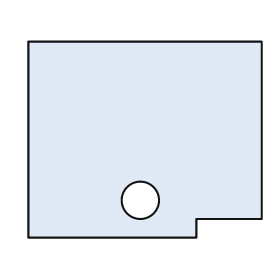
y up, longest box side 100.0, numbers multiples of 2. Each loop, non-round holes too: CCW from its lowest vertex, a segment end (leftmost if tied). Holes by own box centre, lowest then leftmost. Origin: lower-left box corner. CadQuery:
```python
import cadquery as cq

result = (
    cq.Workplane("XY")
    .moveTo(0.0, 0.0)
    .lineTo(72.0, 0.0)
    .lineTo(72.0, 8.0)
    .lineTo(100.0, 8.0)
    .lineTo(100.0, 84.0)
    .lineTo(0.0, 84.0)
    .close()
    .moveTo(48.0, 16.0)
    .circle(8.0)
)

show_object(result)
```